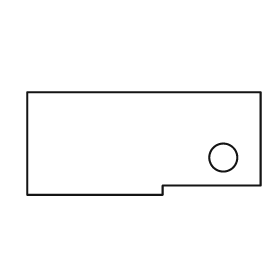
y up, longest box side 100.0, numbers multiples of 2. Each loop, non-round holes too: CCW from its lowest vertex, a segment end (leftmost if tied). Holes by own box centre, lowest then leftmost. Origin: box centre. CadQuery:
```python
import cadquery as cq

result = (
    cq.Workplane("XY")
    .moveTo(-50.0, -22.0)
    .lineTo(8.0, -22.0)
    .lineTo(8.0, -18.0)
    .lineTo(50.0, -18.0)
    .lineTo(50.0, 22.0)
    .lineTo(-50.0, 22.0)
    .close()
    .moveTo(34.0, -6.0)
    .circle(6.0)
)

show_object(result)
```